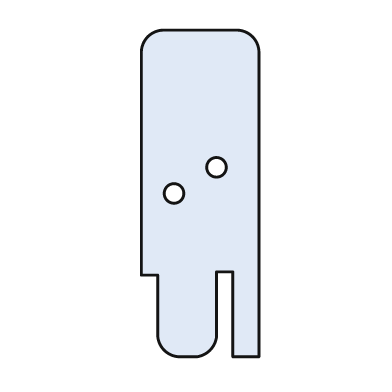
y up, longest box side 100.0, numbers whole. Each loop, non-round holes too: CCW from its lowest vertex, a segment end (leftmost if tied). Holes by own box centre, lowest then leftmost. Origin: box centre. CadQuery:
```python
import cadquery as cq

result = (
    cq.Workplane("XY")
    .moveTo(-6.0, -50.0)
    .lineTo(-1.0, -50.0)
    .threePointArc((3.0, -48.0), (5.0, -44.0))
    .lineTo(5.0, -24.0)
    .lineTo(10.0, -24.0)
    .lineTo(10.0, -50.0)
    .lineTo(18.0, -50.0)
    .lineTo(18.0, 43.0)
    .threePointArc((16.0, 48.0), (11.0, 50.0))
    .lineTo(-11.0, 50.0)
    .threePointArc((-16.0, 48.0), (-18.0, 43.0))
    .lineTo(-18.0, -25.0)
    .lineTo(-13.0, -25.0)
    .lineTo(-13.0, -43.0)
    .threePointArc((-11.0, -48.0), (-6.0, -50.0))
    .close()
    .moveTo(-8.0, 0.0)
    .circle(3.0)
    .moveTo(5.0, 8.0)
    .circle(3.0)
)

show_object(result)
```